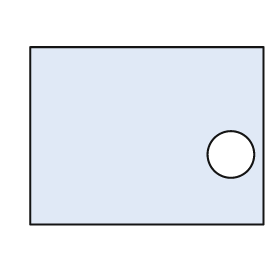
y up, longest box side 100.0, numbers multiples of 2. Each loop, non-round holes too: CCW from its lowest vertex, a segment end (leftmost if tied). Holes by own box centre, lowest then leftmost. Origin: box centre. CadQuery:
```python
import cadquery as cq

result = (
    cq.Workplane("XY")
    .moveTo(-50.0, -38.0)
    .lineTo(50.0, -38.0)
    .lineTo(50.0, 38.0)
    .lineTo(-50.0, 38.0)
    .close()
    .moveTo(36.0, -8.0)
    .circle(10.0)
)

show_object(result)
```